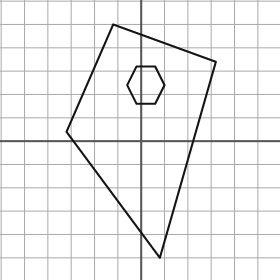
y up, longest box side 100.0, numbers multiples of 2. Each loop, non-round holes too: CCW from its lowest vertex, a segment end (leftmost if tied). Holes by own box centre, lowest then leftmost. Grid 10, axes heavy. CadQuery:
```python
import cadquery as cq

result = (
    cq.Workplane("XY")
    .moveTo(8.0, -50.0)
    .lineTo(32.0, 34.0)
    .lineTo(-12.0, 50.0)
    .lineTo(-32.0, 4.0)
    .close()
    .moveTo(-2.0, 16.0)
    .lineTo(6.0, 16.0)
    .lineTo(10.0, 24.0)
    .lineTo(6.0, 32.0)
    .lineTo(-2.0, 32.0)
    .lineTo(-6.0, 24.0)
    .close()
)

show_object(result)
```